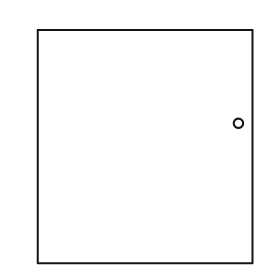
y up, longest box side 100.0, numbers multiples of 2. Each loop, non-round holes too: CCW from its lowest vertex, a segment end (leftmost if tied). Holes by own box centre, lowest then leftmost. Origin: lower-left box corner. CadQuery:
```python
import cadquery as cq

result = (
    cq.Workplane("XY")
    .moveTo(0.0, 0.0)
    .lineTo(92.0, 0.0)
    .lineTo(92.0, 100.0)
    .lineTo(0.0, 100.0)
    .close()
    .moveTo(86.0, 60.0)
    .circle(2.0)
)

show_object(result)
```